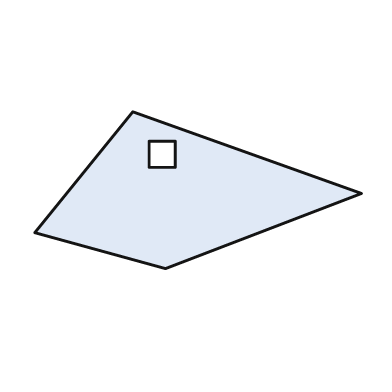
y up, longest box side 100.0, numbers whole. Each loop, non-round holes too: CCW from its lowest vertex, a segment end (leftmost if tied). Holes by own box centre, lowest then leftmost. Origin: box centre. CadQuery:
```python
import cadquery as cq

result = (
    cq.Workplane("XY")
    .moveTo(-10.0, -24.0)
    .lineTo(50.0, -1.0)
    .lineTo(-20.0, 24.0)
    .lineTo(-50.0, -13.0)
    .close()
    .moveTo(-15.0, 7.0)
    .lineTo(-7.0, 7.0)
    .lineTo(-7.0, 15.0)
    .lineTo(-15.0, 15.0)
    .close()
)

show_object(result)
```